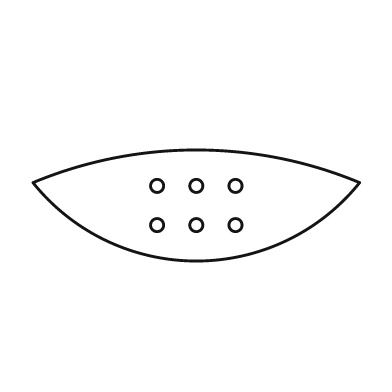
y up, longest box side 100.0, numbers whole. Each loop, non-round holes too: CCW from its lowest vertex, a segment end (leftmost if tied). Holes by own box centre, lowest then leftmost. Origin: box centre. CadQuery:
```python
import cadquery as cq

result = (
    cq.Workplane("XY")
    .moveTo(-50.0, 7.0)
    .threePointArc((0.0, -17.0), (50.0, 7.0))
    .threePointArc((0.0, 17.0), (-50.0, 7.0))
    .close()
    .moveTo(-12.0, -6.0)
    .circle(2.0)
    .moveTo(0.0, -6.0)
    .circle(2.0)
    .moveTo(12.0, -6.0)
    .circle(2.0)
    .moveTo(-12.0, 6.0)
    .circle(2.0)
    .moveTo(0.0, 6.0)
    .circle(2.0)
    .moveTo(12.0, 6.0)
    .circle(2.0)
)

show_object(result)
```